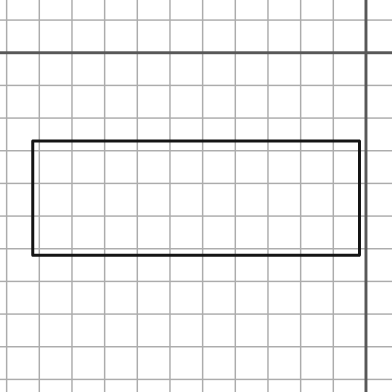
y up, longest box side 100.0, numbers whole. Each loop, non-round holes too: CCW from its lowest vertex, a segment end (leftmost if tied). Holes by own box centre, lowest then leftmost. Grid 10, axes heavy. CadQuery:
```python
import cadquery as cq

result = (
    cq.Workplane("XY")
    .moveTo(-102.0, -62.0)
    .lineTo(-2.0, -62.0)
    .lineTo(-2.0, -27.0)
    .lineTo(-102.0, -27.0)
    .close()
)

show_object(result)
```